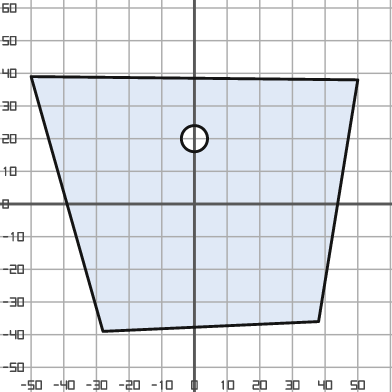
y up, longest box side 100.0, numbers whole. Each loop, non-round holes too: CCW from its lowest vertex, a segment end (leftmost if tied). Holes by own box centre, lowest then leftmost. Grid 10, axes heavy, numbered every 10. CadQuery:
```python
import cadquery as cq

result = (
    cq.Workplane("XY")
    .moveTo(-28.0, -39.0)
    .lineTo(38.0, -36.0)
    .lineTo(50.0, 38.0)
    .lineTo(-50.0, 39.0)
    .close()
    .moveTo(0.0, 20.0)
    .circle(4.0)
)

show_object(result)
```